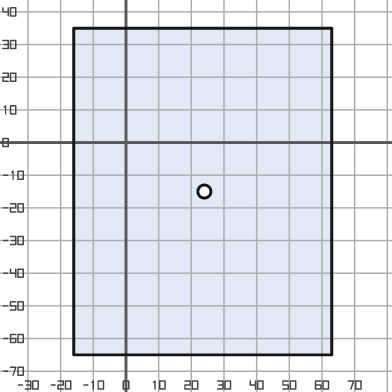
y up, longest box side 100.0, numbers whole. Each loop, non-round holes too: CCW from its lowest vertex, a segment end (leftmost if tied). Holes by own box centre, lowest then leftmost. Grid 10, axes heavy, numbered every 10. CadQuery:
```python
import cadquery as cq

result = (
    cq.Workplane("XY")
    .moveTo(-16.0, -65.0)
    .lineTo(63.0, -65.0)
    .lineTo(63.0, 35.0)
    .lineTo(-16.0, 35.0)
    .close()
    .moveTo(24.0, -15.0)
    .circle(2.0)
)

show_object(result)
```